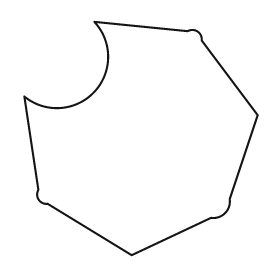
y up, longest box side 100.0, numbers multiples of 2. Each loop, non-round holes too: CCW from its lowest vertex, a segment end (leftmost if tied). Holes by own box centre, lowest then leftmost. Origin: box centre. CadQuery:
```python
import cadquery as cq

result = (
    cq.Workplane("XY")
    .moveTo(-4.0, -50.0)
    .lineTo(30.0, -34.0)
    .threePointArc((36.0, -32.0), (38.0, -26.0))
    .lineTo(50.0, 10.0)
    .lineTo(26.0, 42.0)
    .threePointArc((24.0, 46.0), (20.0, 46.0))
    .lineTo(-20.0, 50.0)
    .threePointArc((-20.0, 20.0), (-50.0, 18.0))
    .lineTo(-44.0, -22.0)
    .threePointArc((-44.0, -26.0), (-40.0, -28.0))
    .close()
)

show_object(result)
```